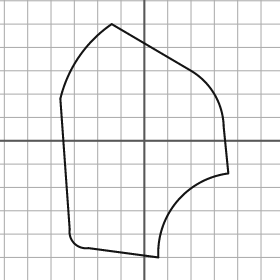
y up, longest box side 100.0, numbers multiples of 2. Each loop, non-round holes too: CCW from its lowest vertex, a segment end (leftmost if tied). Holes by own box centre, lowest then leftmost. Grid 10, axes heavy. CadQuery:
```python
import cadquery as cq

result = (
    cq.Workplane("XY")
    .moveTo(6.0, -50.0)
    .threePointArc((14.0, -26.0), (36.0, -14.0))
    .lineTo(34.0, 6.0)
    .threePointArc((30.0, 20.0), (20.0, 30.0))
    .lineTo(-14.0, 50.0)
    .threePointArc((-28.0, 36.0), (-36.0, 18.0))
    .lineTo(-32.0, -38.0)
    .threePointArc((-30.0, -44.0), (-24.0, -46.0))
    .close()
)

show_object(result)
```